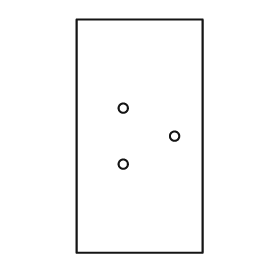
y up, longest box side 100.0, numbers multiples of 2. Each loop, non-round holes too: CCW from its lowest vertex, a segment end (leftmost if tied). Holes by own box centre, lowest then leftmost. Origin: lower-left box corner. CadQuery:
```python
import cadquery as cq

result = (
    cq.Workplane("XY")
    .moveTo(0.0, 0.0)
    .lineTo(54.0, 0.0)
    .lineTo(54.0, 100.0)
    .lineTo(0.0, 100.0)
    .close()
    .moveTo(20.0, 38.0)
    .circle(2.0)
    .moveTo(42.0, 50.0)
    .circle(2.0)
    .moveTo(20.0, 62.0)
    .circle(2.0)
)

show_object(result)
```